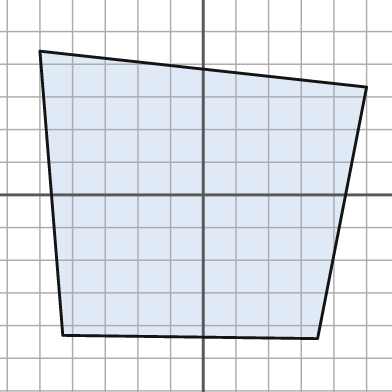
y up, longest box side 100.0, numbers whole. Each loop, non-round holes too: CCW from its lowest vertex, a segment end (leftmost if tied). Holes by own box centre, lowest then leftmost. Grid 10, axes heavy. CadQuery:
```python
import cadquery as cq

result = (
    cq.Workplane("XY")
    .moveTo(35.0, -44.0)
    .lineTo(50.0, 33.0)
    .lineTo(-50.0, 44.0)
    .lineTo(-43.0, -43.0)
    .close()
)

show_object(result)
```